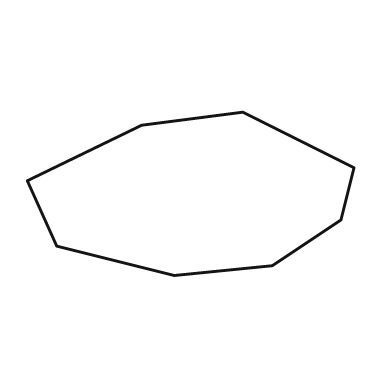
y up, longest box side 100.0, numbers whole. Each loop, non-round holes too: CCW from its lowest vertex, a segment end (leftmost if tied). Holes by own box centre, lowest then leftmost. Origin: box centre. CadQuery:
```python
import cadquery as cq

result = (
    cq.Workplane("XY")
    .moveTo(-5.0, -25.0)
    .lineTo(25.0, -22.0)
    .lineTo(46.0, -8.0)
    .lineTo(50.0, 8.0)
    .lineTo(16.0, 25.0)
    .lineTo(-15.0, 21.0)
    .lineTo(-50.0, 4.0)
    .lineTo(-41.0, -16.0)
    .close()
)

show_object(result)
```